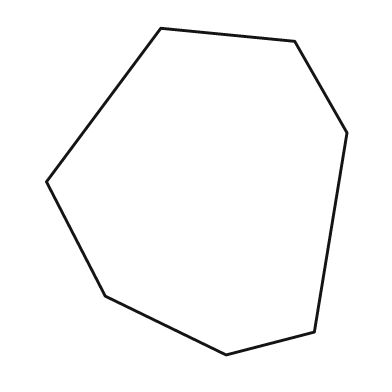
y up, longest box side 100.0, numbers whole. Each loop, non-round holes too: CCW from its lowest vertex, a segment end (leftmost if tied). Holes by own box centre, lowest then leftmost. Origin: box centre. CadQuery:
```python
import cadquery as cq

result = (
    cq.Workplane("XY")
    .moveTo(9.0, -50.0)
    .lineTo(36.0, -43.0)
    .lineTo(46.0, 18.0)
    .lineTo(30.0, 46.0)
    .lineTo(-11.0, 50.0)
    .lineTo(-46.0, 3.0)
    .lineTo(-28.0, -32.0)
    .close()
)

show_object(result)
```